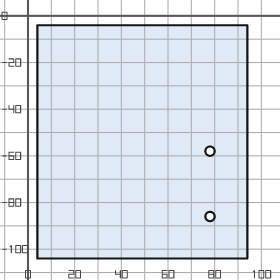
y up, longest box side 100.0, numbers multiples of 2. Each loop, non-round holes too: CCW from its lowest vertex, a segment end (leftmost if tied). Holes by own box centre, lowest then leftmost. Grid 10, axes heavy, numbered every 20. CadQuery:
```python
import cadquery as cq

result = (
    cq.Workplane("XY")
    .moveTo(4.0, -104.0)
    .lineTo(94.0, -104.0)
    .lineTo(94.0, -4.0)
    .lineTo(4.0, -4.0)
    .close()
    .moveTo(78.0, -86.0)
    .circle(2.0)
    .moveTo(78.0, -58.0)
    .circle(2.0)
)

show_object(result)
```